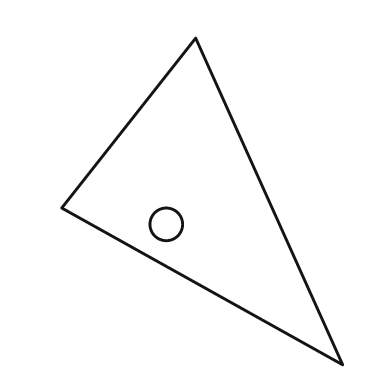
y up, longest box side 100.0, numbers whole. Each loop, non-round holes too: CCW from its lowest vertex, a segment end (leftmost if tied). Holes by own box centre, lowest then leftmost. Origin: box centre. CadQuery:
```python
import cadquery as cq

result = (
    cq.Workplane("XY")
    .moveTo(43.0, -50.0)
    .lineTo(-2.0, 50.0)
    .lineTo(-43.0, -2.0)
    .close()
    .moveTo(-11.0, -7.0)
    .circle(5.0)
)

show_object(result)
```